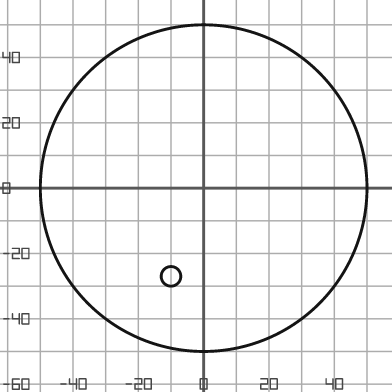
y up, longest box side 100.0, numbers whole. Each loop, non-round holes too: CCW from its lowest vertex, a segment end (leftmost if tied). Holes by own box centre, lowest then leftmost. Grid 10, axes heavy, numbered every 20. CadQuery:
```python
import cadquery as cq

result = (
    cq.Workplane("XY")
    .moveTo(0.0, 0.0)
    .circle(50.0)
    .moveTo(-10.0, -27.0)
    .circle(3.0)
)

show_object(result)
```